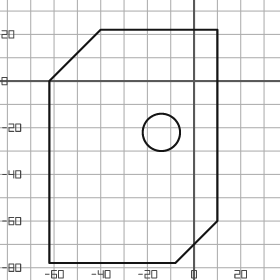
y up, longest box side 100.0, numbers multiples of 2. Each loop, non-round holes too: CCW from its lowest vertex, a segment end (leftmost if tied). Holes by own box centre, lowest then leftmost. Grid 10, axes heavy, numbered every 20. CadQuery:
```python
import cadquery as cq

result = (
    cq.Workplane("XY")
    .moveTo(-62.0, -78.0)
    .lineTo(-8.0, -78.0)
    .lineTo(10.0, -60.0)
    .lineTo(10.0, 22.0)
    .lineTo(-40.0, 22.0)
    .lineTo(-62.0, 0.0)
    .close()
    .moveTo(-14.0, -22.0)
    .circle(8.0)
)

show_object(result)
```